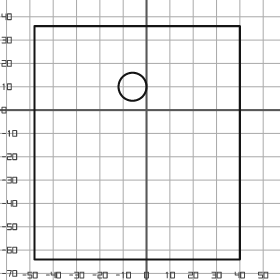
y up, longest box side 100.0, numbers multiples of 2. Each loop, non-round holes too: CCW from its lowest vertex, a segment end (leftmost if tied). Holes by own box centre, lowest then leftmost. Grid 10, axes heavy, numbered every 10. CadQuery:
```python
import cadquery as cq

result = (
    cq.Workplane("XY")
    .moveTo(-48.0, -64.0)
    .lineTo(40.0, -64.0)
    .lineTo(40.0, 36.0)
    .lineTo(-48.0, 36.0)
    .close()
    .moveTo(-6.0, 10.0)
    .circle(6.0)
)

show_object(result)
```